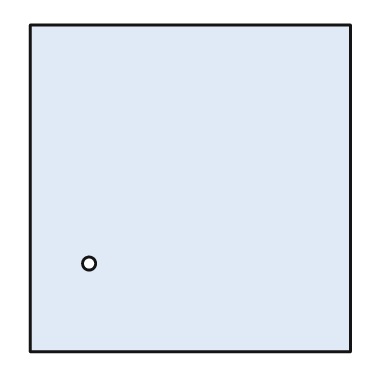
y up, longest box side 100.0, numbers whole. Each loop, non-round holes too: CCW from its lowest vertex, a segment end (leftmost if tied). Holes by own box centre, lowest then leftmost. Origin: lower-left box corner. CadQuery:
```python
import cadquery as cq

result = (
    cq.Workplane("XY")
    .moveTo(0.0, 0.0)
    .lineTo(98.0, 0.0)
    .lineTo(98.0, 100.0)
    .lineTo(0.0, 100.0)
    .close()
    .moveTo(18.0, 27.0)
    .circle(2.0)
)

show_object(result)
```